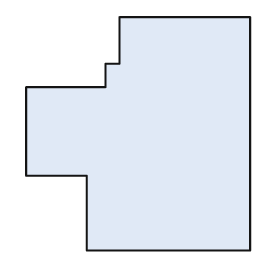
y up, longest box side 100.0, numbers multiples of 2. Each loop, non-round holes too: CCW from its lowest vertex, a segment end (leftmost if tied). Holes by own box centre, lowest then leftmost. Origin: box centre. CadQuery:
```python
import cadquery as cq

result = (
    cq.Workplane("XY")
    .moveTo(-22.0, -50.0)
    .lineTo(48.0, -50.0)
    .lineTo(48.0, 50.0)
    .lineTo(-8.0, 50.0)
    .lineTo(-8.0, 30.0)
    .lineTo(-14.0, 30.0)
    .lineTo(-14.0, 20.0)
    .lineTo(-48.0, 20.0)
    .lineTo(-48.0, -18.0)
    .lineTo(-22.0, -18.0)
    .close()
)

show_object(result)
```